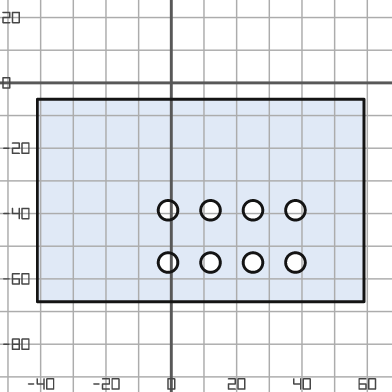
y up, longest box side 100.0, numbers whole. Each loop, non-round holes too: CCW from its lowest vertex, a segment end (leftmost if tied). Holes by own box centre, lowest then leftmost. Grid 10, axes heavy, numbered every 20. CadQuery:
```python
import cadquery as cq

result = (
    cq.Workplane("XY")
    .moveTo(-41.0, -67.0)
    .lineTo(59.0, -67.0)
    .lineTo(59.0, -5.0)
    .lineTo(-41.0, -5.0)
    .close()
    .moveTo(-1.0, -55.0)
    .circle(3.0)
    .moveTo(12.0, -55.0)
    .circle(3.0)
    .moveTo(25.0, -55.0)
    .circle(3.0)
    .moveTo(38.0, -55.0)
    .circle(3.0)
    .moveTo(-1.0, -39.0)
    .circle(3.0)
    .moveTo(12.0, -39.0)
    .circle(3.0)
    .moveTo(25.0, -39.0)
    .circle(3.0)
    .moveTo(38.0, -39.0)
    .circle(3.0)
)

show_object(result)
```